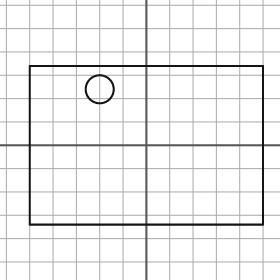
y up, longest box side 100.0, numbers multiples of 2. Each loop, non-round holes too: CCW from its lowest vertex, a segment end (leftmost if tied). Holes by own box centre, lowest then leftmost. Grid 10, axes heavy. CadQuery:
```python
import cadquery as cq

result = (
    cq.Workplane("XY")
    .moveTo(-50.0, -34.0)
    .lineTo(50.0, -34.0)
    .lineTo(50.0, 34.0)
    .lineTo(-50.0, 34.0)
    .close()
    .moveTo(-20.0, 24.0)
    .circle(6.0)
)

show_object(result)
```